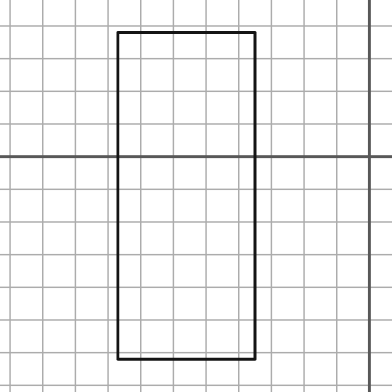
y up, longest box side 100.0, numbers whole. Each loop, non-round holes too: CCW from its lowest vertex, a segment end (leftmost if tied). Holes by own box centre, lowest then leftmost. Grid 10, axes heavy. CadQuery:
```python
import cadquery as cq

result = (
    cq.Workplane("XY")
    .moveTo(-77.0, -62.0)
    .lineTo(-35.0, -62.0)
    .lineTo(-35.0, 38.0)
    .lineTo(-77.0, 38.0)
    .close()
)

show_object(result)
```